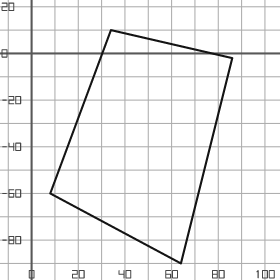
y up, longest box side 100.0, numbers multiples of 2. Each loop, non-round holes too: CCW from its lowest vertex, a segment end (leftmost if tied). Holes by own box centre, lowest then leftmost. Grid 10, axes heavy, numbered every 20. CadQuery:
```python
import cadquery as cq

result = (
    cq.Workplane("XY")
    .moveTo(64.0, -90.0)
    .lineTo(86.0, -2.0)
    .lineTo(34.0, 10.0)
    .lineTo(8.0, -60.0)
    .close()
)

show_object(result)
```